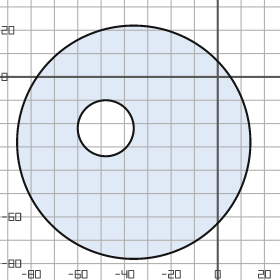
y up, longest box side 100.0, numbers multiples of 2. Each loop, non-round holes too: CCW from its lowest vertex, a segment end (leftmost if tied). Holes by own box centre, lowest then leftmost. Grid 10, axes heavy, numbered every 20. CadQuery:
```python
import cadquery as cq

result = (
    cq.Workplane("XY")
    .moveTo(-36.0, -28.0)
    .circle(50.0)
    .moveTo(-48.0, -22.0)
    .circle(12.0)
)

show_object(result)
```